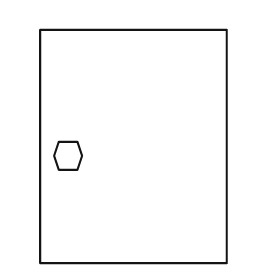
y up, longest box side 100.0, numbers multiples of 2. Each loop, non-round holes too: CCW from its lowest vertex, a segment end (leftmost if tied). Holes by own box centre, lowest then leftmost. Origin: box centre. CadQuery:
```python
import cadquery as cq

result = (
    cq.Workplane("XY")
    .moveTo(-40.0, -50.0)
    .lineTo(40.0, -50.0)
    .lineTo(40.0, 50.0)
    .lineTo(-40.0, 50.0)
    .close()
    .moveTo(-32.0, -10.0)
    .lineTo(-24.0, -10.0)
    .lineTo(-22.0, -4.0)
    .lineTo(-24.0, 2.0)
    .lineTo(-32.0, 2.0)
    .lineTo(-34.0, -4.0)
    .close()
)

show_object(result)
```